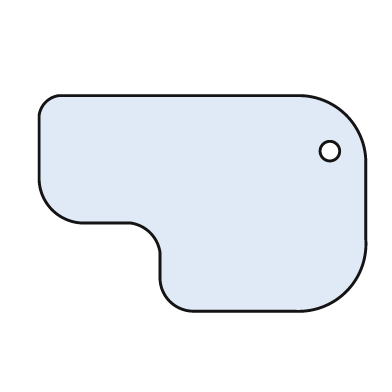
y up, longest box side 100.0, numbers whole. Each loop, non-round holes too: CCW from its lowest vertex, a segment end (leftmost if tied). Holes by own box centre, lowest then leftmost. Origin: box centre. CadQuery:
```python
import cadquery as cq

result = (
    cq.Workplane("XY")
    .moveTo(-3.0, -33.0)
    .lineTo(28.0, -33.0)
    .threePointArc((44.0, -27.0), (50.0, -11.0))
    .lineTo(50.0, 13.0)
    .threePointArc((44.0, 27.0), (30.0, 33.0))
    .lineTo(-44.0, 33.0)
    .threePointArc((-48.0, 31.0), (-50.0, 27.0))
    .lineTo(-50.0, 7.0)
    .threePointArc((-46.0, -2.0), (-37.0, -6.0))
    .lineTo(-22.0, -6.0)
    .threePointArc((-16.0, -9.0), (-13.0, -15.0))
    .lineTo(-13.0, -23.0)
    .threePointArc((-10.0, -30.0), (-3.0, -33.0))
    .close()
    .moveTo(39.0, 16.0)
    .circle(3.0)
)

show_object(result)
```